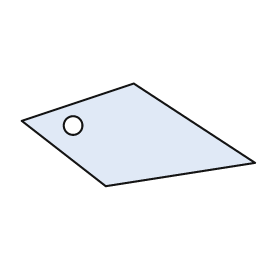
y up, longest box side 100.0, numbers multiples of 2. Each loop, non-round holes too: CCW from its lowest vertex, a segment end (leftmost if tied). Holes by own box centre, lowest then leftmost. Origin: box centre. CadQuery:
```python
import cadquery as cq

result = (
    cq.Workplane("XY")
    .moveTo(-14.0, -22.0)
    .lineTo(50.0, -12.0)
    .lineTo(-2.0, 22.0)
    .lineTo(-50.0, 6.0)
    .close()
    .moveTo(-28.0, 4.0)
    .circle(4.0)
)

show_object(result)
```